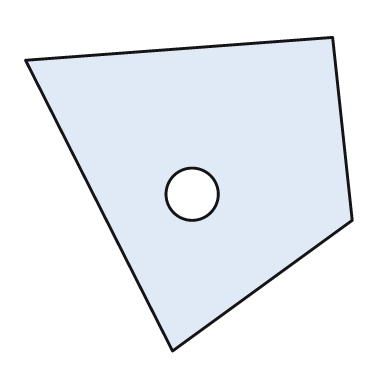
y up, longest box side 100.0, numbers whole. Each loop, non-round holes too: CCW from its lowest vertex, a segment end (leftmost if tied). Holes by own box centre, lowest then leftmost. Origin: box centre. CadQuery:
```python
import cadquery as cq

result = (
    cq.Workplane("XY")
    .moveTo(-5.0, -48.0)
    .lineTo(50.0, -8.0)
    .lineTo(44.0, 48.0)
    .lineTo(-50.0, 41.0)
    .close()
    .moveTo(1.0, 0.0)
    .circle(8.0)
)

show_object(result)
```